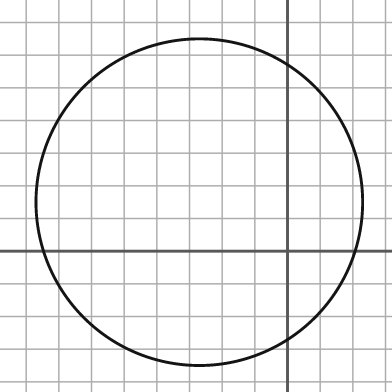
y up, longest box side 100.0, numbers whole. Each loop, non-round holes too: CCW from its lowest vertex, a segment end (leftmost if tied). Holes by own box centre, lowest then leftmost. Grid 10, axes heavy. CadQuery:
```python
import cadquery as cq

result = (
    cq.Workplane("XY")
    .moveTo(-27.0, 15.0)
    .circle(50.0)
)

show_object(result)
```